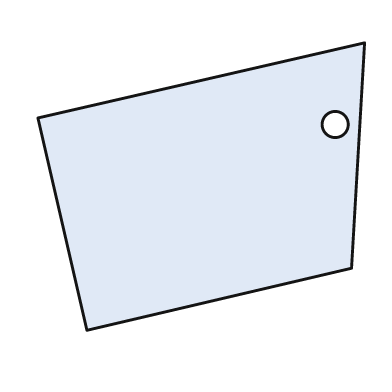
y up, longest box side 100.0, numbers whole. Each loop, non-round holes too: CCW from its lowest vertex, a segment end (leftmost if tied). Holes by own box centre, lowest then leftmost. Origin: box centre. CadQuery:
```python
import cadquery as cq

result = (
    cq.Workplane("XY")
    .moveTo(-35.0, -44.0)
    .lineTo(46.0, -25.0)
    .lineTo(50.0, 44.0)
    .lineTo(-50.0, 21.0)
    .close()
    .moveTo(41.0, 19.0)
    .circle(4.0)
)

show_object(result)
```